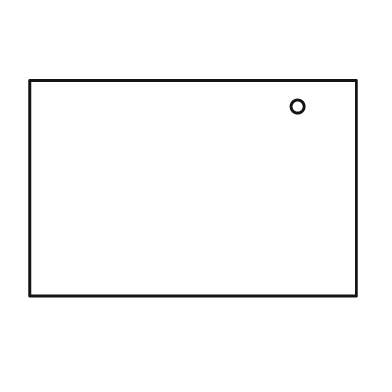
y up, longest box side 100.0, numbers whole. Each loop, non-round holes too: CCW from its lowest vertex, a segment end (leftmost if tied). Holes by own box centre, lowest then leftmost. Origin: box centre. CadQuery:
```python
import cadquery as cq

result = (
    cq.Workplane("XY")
    .moveTo(-50.0, -33.0)
    .lineTo(50.0, -33.0)
    .lineTo(50.0, 33.0)
    .lineTo(-50.0, 33.0)
    .close()
    .moveTo(32.0, 25.0)
    .circle(2.0)
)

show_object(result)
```